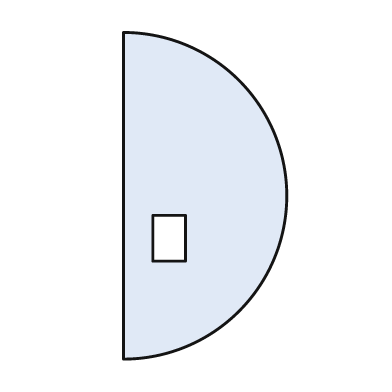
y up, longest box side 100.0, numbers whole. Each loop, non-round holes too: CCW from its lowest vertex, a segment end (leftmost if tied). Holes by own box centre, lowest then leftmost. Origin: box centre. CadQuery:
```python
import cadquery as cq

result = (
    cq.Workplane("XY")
    .moveTo(-25.0, -50.0)
    .threePointArc((25.0, 0.0), (-25.0, 50.0))
    .close()
    .moveTo(-16.0, -20.0)
    .lineTo(-6.0, -20.0)
    .lineTo(-6.0, -6.0)
    .lineTo(-16.0, -6.0)
    .close()
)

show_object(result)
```